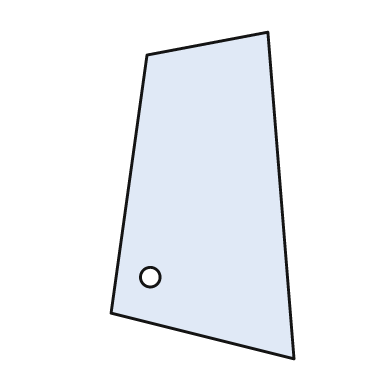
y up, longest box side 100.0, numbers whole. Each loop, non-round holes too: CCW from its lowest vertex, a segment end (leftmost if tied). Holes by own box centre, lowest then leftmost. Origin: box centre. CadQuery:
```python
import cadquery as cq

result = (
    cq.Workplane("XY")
    .moveTo(28.0, -50.0)
    .lineTo(20.0, 50.0)
    .lineTo(-17.0, 43.0)
    .lineTo(-28.0, -36.0)
    .close()
    .moveTo(-16.0, -25.0)
    .circle(3.0)
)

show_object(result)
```